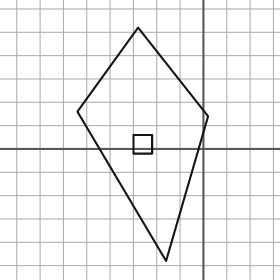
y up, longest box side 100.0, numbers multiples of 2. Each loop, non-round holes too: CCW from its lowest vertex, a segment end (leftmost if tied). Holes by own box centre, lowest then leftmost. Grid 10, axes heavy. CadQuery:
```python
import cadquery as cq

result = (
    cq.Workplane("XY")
    .moveTo(-16.0, -48.0)
    .lineTo(2.0, 14.0)
    .lineTo(-28.0, 52.0)
    .lineTo(-54.0, 16.0)
    .close()
    .moveTo(-30.0, -2.0)
    .lineTo(-22.0, -2.0)
    .lineTo(-22.0, 6.0)
    .lineTo(-30.0, 6.0)
    .close()
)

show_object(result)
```